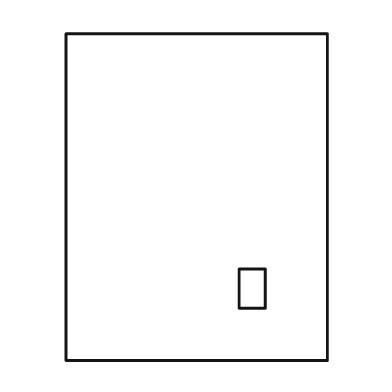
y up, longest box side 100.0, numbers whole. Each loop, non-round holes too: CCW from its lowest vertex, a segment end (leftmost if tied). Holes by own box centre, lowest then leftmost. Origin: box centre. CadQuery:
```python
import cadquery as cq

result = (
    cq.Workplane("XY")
    .moveTo(-40.0, -50.0)
    .lineTo(40.0, -50.0)
    .lineTo(40.0, 50.0)
    .lineTo(-40.0, 50.0)
    .close()
    .moveTo(13.0, -34.0)
    .lineTo(21.0, -34.0)
    .lineTo(21.0, -22.0)
    .lineTo(13.0, -22.0)
    .close()
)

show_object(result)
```